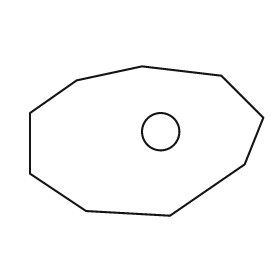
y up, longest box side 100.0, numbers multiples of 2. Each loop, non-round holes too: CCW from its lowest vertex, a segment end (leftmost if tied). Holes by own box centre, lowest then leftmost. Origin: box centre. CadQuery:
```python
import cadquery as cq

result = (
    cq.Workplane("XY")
    .moveTo(10.0, -32.0)
    .lineTo(42.0, -10.0)
    .lineTo(50.0, 10.0)
    .lineTo(32.0, 28.0)
    .lineTo(-2.0, 32.0)
    .lineTo(-30.0, 26.0)
    .lineTo(-50.0, 12.0)
    .lineTo(-50.0, -14.0)
    .lineTo(-26.0, -30.0)
    .close()
    .moveTo(6.0, 4.0)
    .circle(8.0)
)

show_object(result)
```